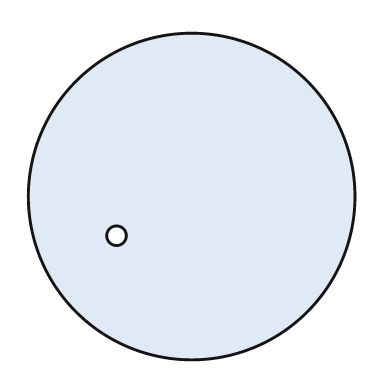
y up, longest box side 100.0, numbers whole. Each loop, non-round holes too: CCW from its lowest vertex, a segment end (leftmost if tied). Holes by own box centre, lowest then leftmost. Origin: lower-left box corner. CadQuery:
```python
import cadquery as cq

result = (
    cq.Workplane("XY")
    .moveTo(50.0, 50.0)
    .circle(50.0)
    .moveTo(27.0, 38.0)
    .circle(3.0)
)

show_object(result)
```